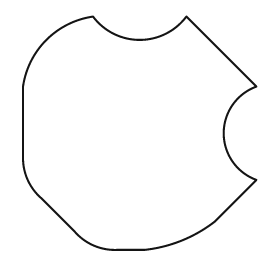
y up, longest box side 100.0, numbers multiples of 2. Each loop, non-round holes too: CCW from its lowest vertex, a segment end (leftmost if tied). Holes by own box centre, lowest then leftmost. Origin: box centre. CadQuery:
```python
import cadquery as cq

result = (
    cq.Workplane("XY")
    .moveTo(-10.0, -50.0)
    .lineTo(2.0, -50.0)
    .threePointArc((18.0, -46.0), (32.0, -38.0))
    .lineTo(50.0, -20.0)
    .threePointArc((36.0, 0.0), (50.0, 20.0))
    .lineTo(20.0, 50.0)
    .threePointArc((0.0, 40.0), (-20.0, 50.0))
    .threePointArc((-40.0, 40.0), (-50.0, 20.0))
    .lineTo(-50.0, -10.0)
    .threePointArc((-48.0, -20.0), (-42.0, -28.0))
    .lineTo(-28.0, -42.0)
    .threePointArc((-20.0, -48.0), (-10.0, -50.0))
    .close()
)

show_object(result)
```